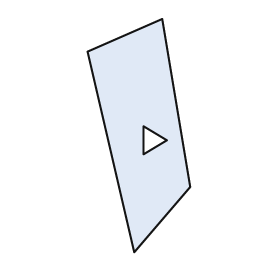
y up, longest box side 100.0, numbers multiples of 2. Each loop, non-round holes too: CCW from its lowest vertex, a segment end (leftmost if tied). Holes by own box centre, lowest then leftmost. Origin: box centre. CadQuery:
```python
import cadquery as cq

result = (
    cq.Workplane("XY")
    .moveTo(-2.0, -50.0)
    .lineTo(22.0, -22.0)
    .lineTo(10.0, 50.0)
    .lineTo(-22.0, 36.0)
    .close()
    .moveTo(2.0, -8.0)
    .lineTo(12.0, -2.0)
    .lineTo(2.0, 4.0)
    .close()
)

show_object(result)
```